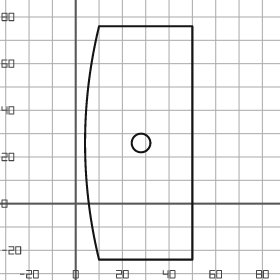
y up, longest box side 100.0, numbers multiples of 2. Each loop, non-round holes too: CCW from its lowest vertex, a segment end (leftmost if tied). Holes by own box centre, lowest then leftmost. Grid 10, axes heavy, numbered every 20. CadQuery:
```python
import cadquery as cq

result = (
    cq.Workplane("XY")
    .moveTo(10.0, -24.0)
    .lineTo(50.0, -24.0)
    .lineTo(50.0, 76.0)
    .lineTo(10.0, 76.0)
    .threePointArc((4.0, 26.0), (10.0, -24.0))
    .close()
    .moveTo(28.0, 26.0)
    .circle(4.0)
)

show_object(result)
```